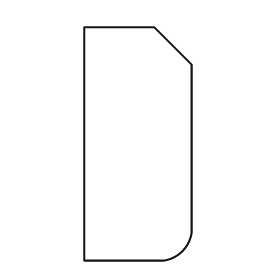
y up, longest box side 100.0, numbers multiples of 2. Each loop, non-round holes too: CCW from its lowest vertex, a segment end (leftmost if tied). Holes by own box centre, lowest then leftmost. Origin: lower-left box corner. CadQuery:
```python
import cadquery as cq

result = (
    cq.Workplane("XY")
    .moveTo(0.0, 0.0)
    .lineTo(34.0, 0.0)
    .threePointArc((42.0, 4.0), (46.0, 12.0))
    .lineTo(46.0, 84.0)
    .lineTo(30.0, 100.0)
    .lineTo(0.0, 100.0)
    .close()
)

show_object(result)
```